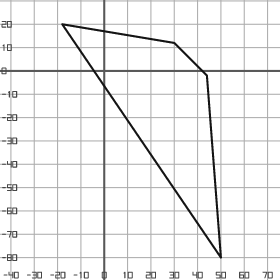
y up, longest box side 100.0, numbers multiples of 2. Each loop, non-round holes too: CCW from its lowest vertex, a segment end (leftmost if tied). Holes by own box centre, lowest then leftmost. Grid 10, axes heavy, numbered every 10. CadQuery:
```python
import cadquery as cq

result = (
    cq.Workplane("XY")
    .moveTo(50.0, -80.0)
    .lineTo(44.0, -2.0)
    .lineTo(30.0, 12.0)
    .lineTo(-18.0, 20.0)
    .close()
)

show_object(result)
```